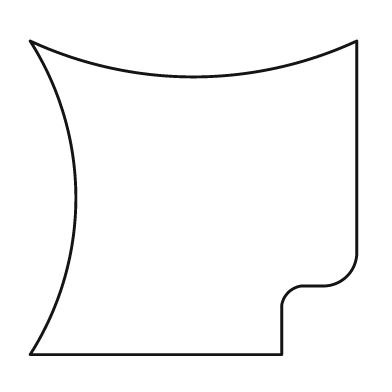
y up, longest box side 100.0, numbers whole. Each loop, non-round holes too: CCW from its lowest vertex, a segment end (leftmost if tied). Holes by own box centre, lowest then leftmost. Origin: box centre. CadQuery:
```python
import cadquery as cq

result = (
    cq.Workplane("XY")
    .moveTo(-50.0, -48.0)
    .lineTo(27.0, -48.0)
    .lineTo(27.0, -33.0)
    .threePointArc((29.0, -29.0), (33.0, -27.0))
    .lineTo(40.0, -27.0)
    .threePointArc((47.0, -24.0), (50.0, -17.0))
    .lineTo(50.0, 48.0)
    .threePointArc((0.0, 37.0), (-50.0, 48.0))
    .threePointArc((-36.0, 0.0), (-50.0, -48.0))
    .close()
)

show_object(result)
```